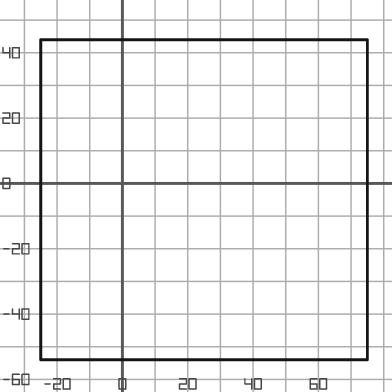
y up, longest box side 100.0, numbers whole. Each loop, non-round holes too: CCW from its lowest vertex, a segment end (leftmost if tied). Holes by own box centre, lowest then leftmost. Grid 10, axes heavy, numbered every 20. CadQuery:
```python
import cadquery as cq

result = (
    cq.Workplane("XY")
    .moveTo(-25.0, -54.0)
    .lineTo(75.0, -54.0)
    .lineTo(75.0, 44.0)
    .lineTo(-25.0, 44.0)
    .close()
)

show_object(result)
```